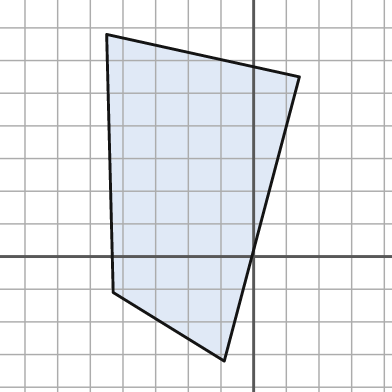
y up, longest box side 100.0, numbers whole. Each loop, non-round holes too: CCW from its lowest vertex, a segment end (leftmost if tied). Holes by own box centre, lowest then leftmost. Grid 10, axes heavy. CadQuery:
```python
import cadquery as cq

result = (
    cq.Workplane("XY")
    .moveTo(-9.0, -32.0)
    .lineTo(14.0, 55.0)
    .lineTo(-45.0, 68.0)
    .lineTo(-43.0, -11.0)
    .close()
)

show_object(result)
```